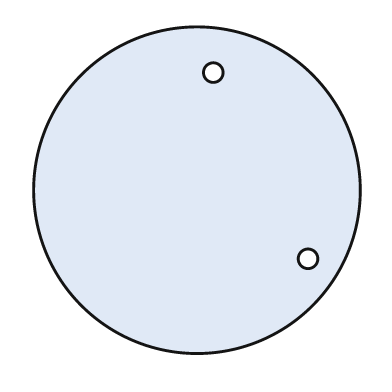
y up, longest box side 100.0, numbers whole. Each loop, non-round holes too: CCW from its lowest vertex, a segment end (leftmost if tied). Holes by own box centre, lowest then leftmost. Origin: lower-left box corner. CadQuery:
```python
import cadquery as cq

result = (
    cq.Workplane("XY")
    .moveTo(50.0, 50.0)
    .circle(50.0)
    .moveTo(84.0, 29.0)
    .circle(3.0)
    .moveTo(55.0, 86.0)
    .circle(3.0)
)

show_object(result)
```